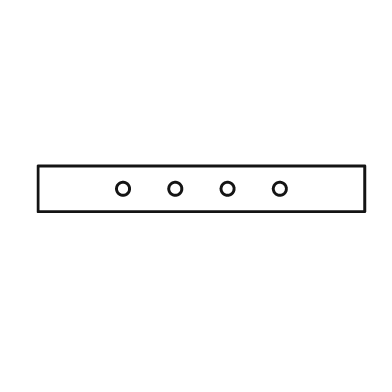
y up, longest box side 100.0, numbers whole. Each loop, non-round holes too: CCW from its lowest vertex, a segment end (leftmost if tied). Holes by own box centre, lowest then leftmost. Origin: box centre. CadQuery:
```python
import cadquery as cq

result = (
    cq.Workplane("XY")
    .moveTo(-50.0, -7.0)
    .lineTo(50.0, -7.0)
    .lineTo(50.0, 7.0)
    .lineTo(-50.0, 7.0)
    .close()
    .moveTo(-24.0, 0.0)
    .circle(2.0)
    .moveTo(-8.0, 0.0)
    .circle(2.0)
    .moveTo(8.0, 0.0)
    .circle(2.0)
    .moveTo(24.0, 0.0)
    .circle(2.0)
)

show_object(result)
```